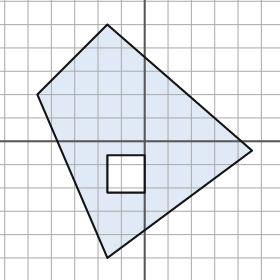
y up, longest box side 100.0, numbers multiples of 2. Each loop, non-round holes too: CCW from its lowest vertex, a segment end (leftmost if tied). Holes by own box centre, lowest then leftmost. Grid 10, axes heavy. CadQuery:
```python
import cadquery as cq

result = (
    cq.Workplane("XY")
    .moveTo(-16.0, -50.0)
    .lineTo(46.0, -4.0)
    .lineTo(-16.0, 50.0)
    .lineTo(-46.0, 20.0)
    .close()
    .moveTo(-16.0, -22.0)
    .lineTo(0.0, -22.0)
    .lineTo(0.0, -6.0)
    .lineTo(-16.0, -6.0)
    .close()
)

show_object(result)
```